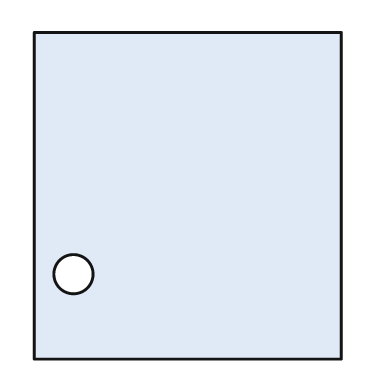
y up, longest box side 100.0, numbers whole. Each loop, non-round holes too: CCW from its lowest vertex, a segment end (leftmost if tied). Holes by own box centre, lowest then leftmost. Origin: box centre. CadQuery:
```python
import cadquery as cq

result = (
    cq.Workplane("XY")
    .moveTo(-47.0, -50.0)
    .lineTo(47.0, -50.0)
    .lineTo(47.0, 50.0)
    .lineTo(-47.0, 50.0)
    .close()
    .moveTo(-35.0, -24.0)
    .circle(6.0)
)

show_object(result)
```